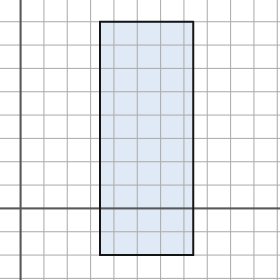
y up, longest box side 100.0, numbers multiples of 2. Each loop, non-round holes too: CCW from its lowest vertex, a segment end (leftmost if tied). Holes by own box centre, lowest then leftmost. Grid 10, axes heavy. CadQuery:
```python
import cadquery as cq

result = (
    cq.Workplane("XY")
    .moveTo(34.0, -20.0)
    .lineTo(74.0, -20.0)
    .lineTo(74.0, 80.0)
    .lineTo(34.0, 80.0)
    .close()
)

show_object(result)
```